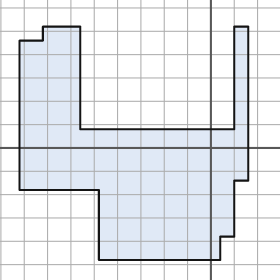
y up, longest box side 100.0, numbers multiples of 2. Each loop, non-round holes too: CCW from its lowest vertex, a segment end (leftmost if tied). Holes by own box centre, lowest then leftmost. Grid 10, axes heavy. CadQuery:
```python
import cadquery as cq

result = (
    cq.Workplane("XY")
    .moveTo(-48.0, -48.0)
    .lineTo(4.0, -48.0)
    .lineTo(4.0, -38.0)
    .lineTo(10.0, -38.0)
    .lineTo(10.0, -14.0)
    .lineTo(16.0, -14.0)
    .lineTo(16.0, 52.0)
    .lineTo(10.0, 52.0)
    .lineTo(10.0, 8.0)
    .lineTo(-56.0, 8.0)
    .lineTo(-56.0, 52.0)
    .lineTo(-72.0, 52.0)
    .lineTo(-72.0, 46.0)
    .lineTo(-82.0, 46.0)
    .lineTo(-82.0, -18.0)
    .lineTo(-48.0, -18.0)
    .close()
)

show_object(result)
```